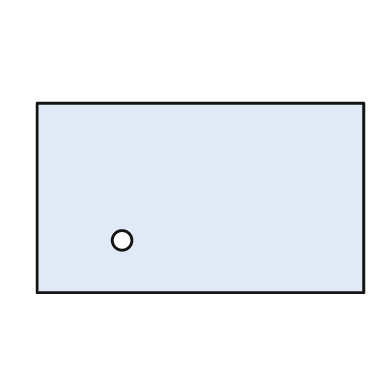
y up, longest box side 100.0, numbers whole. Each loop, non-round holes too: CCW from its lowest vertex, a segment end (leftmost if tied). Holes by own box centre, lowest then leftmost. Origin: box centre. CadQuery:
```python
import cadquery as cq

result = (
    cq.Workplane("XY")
    .moveTo(-50.0, -29.0)
    .lineTo(50.0, -29.0)
    .lineTo(50.0, 29.0)
    .lineTo(-50.0, 29.0)
    .close()
    .moveTo(-24.0, -13.0)
    .circle(3.0)
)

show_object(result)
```